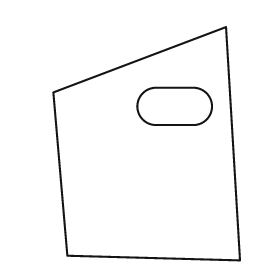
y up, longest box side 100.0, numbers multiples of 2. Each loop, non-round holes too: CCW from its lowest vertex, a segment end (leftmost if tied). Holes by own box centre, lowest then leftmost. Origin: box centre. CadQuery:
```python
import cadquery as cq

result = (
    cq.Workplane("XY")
    .moveTo(40.0, -50.0)
    .lineTo(34.0, 50.0)
    .lineTo(-40.0, 22.0)
    .lineTo(-34.0, -48.0)
    .close()
    .moveTo(4.0, 8.0)
    .lineTo(20.0, 8.0)
    .threePointArc((28.0, 16.0), (20.0, 24.0))
    .lineTo(4.0, 24.0)
    .threePointArc((-4.0, 16.0), (4.0, 8.0))
    .close()
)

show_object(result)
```